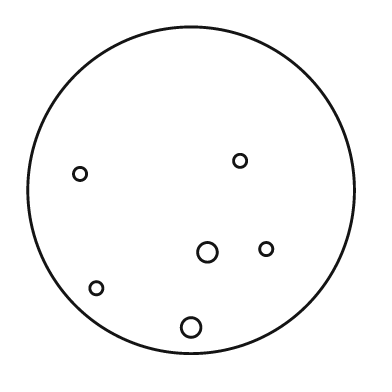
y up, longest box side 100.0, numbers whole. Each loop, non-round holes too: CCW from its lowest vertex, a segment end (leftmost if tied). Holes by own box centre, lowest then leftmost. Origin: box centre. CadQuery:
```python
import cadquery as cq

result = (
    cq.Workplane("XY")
    .moveTo(0.0, 0.0)
    .circle(50.0)
    .moveTo(0.0, -42.0)
    .circle(3.0)
    .moveTo(-29.0, -30.0)
    .circle(2.0)
    .moveTo(5.0, -19.0)
    .circle(3.0)
    .moveTo(23.0, -18.0)
    .circle(2.0)
    .moveTo(-34.0, 5.0)
    .circle(2.0)
    .moveTo(15.0, 9.0)
    .circle(2.0)
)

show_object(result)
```